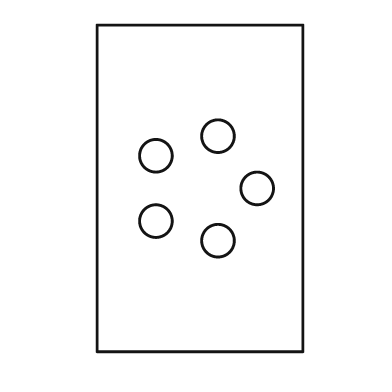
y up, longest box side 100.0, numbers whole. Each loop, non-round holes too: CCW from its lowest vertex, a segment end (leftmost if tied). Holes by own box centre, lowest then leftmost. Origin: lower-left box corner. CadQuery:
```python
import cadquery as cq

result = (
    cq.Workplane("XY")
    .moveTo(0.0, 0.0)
    .lineTo(63.0, 0.0)
    .lineTo(63.0, 100.0)
    .lineTo(0.0, 100.0)
    .close()
    .moveTo(37.0, 34.0)
    .circle(5.0)
    .moveTo(18.0, 40.0)
    .circle(5.0)
    .moveTo(49.0, 50.0)
    .circle(5.0)
    .moveTo(18.0, 60.0)
    .circle(5.0)
    .moveTo(37.0, 66.0)
    .circle(5.0)
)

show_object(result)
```